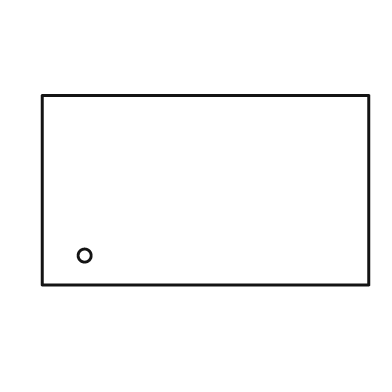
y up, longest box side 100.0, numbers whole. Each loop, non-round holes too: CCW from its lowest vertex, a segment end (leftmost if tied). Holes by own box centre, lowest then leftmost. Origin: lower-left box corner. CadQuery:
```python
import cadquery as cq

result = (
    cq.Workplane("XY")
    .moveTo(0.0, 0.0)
    .lineTo(100.0, 0.0)
    .lineTo(100.0, 58.0)
    .lineTo(0.0, 58.0)
    .close()
    .moveTo(13.0, 9.0)
    .circle(2.0)
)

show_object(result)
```